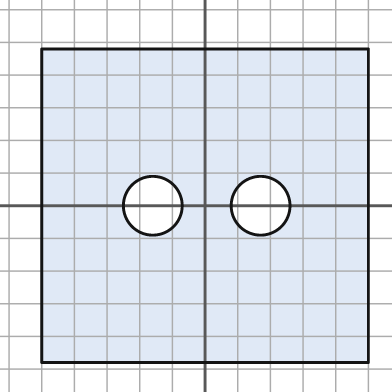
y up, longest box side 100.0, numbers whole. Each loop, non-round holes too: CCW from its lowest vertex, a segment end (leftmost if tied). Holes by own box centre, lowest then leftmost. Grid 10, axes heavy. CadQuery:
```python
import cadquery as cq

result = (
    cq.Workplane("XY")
    .moveTo(-50.0, -48.0)
    .lineTo(50.0, -48.0)
    .lineTo(50.0, 48.0)
    .lineTo(-50.0, 48.0)
    .close()
    .moveTo(-16.0, 0.0)
    .circle(9.0)
    .moveTo(17.0, 0.0)
    .circle(9.0)
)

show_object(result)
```